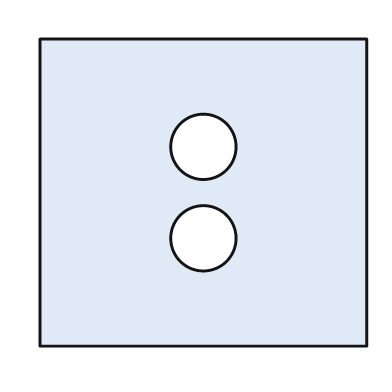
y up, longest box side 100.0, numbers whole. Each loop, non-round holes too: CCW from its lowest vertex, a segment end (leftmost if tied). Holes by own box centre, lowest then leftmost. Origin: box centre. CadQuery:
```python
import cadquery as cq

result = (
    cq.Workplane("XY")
    .moveTo(-50.0, -47.0)
    .lineTo(50.0, -47.0)
    .lineTo(50.0, 47.0)
    .lineTo(-50.0, 47.0)
    .close()
    .moveTo(0.0, -14.0)
    .circle(10.0)
    .moveTo(0.0, 14.0)
    .circle(10.0)
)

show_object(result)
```